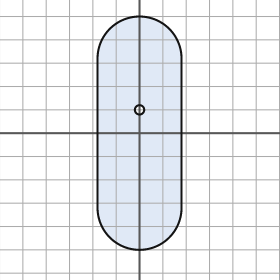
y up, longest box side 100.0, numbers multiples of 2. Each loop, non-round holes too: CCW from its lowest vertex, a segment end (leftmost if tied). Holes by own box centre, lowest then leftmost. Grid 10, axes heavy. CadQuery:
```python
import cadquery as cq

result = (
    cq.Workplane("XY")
    .moveTo(-18.0, -32.0)
    .threePointArc((0.0, -50.0), (18.0, -32.0))
    .lineTo(18.0, 32.0)
    .threePointArc((0.0, 50.0), (-18.0, 32.0))
    .close()
    .moveTo(0.0, 10.0)
    .circle(2.0)
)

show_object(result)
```